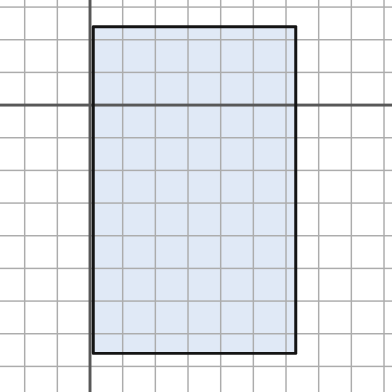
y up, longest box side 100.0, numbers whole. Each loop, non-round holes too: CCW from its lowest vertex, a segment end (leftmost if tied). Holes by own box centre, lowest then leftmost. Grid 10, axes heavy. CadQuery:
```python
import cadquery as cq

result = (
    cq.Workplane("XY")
    .moveTo(1.0, -76.0)
    .lineTo(63.0, -76.0)
    .lineTo(63.0, 24.0)
    .lineTo(1.0, 24.0)
    .close()
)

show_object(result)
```